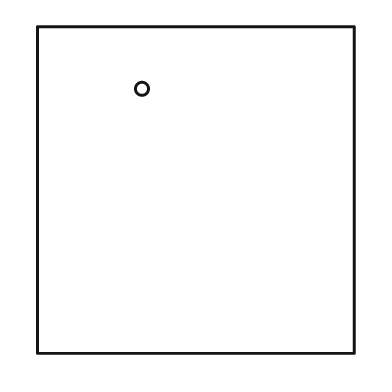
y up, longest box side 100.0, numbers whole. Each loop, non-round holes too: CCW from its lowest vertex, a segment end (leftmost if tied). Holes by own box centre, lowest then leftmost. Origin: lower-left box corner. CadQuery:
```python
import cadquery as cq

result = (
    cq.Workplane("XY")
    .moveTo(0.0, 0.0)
    .lineTo(97.0, 0.0)
    .lineTo(97.0, 100.0)
    .lineTo(0.0, 100.0)
    .close()
    .moveTo(32.0, 81.0)
    .circle(2.0)
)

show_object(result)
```